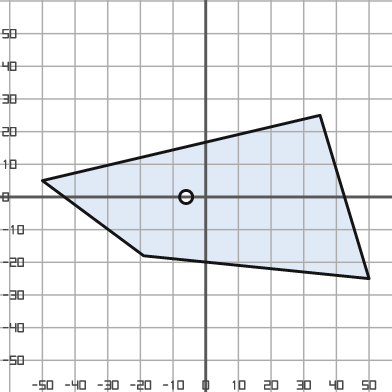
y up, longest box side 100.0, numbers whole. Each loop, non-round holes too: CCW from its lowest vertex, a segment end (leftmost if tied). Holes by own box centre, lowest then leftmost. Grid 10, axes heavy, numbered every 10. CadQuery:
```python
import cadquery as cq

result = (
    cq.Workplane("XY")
    .moveTo(50.0, -25.0)
    .lineTo(35.0, 25.0)
    .lineTo(-50.0, 5.0)
    .lineTo(-19.0, -18.0)
    .close()
    .moveTo(-6.0, 0.0)
    .circle(2.0)
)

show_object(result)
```